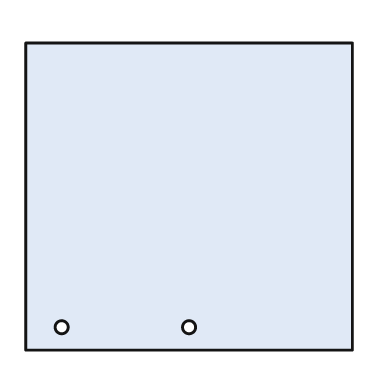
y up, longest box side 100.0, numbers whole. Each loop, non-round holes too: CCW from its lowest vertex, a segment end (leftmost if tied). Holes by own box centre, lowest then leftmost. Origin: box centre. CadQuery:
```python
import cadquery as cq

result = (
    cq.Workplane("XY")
    .moveTo(-50.0, -47.0)
    .lineTo(50.0, -47.0)
    .lineTo(50.0, 47.0)
    .lineTo(-50.0, 47.0)
    .close()
    .moveTo(-39.0, -40.0)
    .circle(2.0)
    .moveTo(0.0, -40.0)
    .circle(2.0)
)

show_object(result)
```